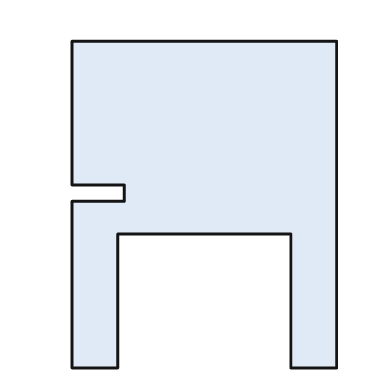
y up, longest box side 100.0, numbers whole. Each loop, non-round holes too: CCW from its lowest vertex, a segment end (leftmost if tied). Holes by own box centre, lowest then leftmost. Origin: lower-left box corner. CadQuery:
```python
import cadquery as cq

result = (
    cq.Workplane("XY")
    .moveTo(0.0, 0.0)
    .lineTo(14.0, 0.0)
    .lineTo(14.0, 41.0)
    .lineTo(67.0, 41.0)
    .lineTo(67.0, 0.0)
    .lineTo(81.0, 0.0)
    .lineTo(81.0, 100.0)
    .lineTo(0.0, 100.0)
    .lineTo(0.0, 56.0)
    .lineTo(16.0, 56.0)
    .lineTo(16.0, 51.0)
    .lineTo(0.0, 51.0)
    .close()
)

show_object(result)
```